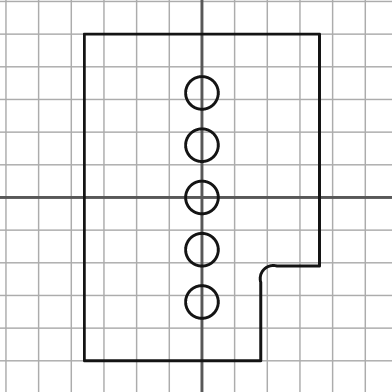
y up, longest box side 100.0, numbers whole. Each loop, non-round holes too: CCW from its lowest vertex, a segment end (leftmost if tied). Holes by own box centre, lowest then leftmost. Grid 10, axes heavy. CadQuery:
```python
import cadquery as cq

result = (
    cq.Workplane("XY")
    .moveTo(-36.0, -50.0)
    .lineTo(18.0, -50.0)
    .lineTo(18.0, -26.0)
    .threePointArc((19.0, -22.0), (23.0, -21.0))
    .lineTo(36.0, -21.0)
    .lineTo(36.0, 50.0)
    .lineTo(-36.0, 50.0)
    .close()
    .moveTo(0.0, -32.0)
    .circle(5.0)
    .moveTo(0.0, -16.0)
    .circle(5.0)
    .moveTo(0.0, 0.0)
    .circle(5.0)
    .moveTo(0.0, 16.0)
    .circle(5.0)
    .moveTo(0.0, 32.0)
    .circle(5.0)
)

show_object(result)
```